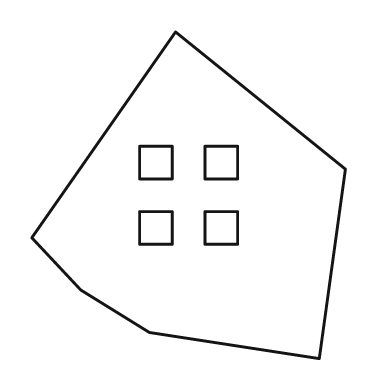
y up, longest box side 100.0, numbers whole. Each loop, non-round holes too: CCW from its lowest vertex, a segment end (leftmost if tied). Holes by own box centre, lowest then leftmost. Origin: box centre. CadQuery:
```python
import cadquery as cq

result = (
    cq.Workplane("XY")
    .moveTo(40.0, -50.0)
    .lineTo(48.0, 8.0)
    .lineTo(-4.0, 50.0)
    .lineTo(-48.0, -13.0)
    .lineTo(-33.0, -29.0)
    .lineTo(-12.0, -42.0)
    .close()
    .moveTo(-15.0, -15.0)
    .lineTo(-5.0, -15.0)
    .lineTo(-5.0, -5.0)
    .lineTo(-15.0, -5.0)
    .close()
    .moveTo(5.0, -15.0)
    .lineTo(15.0, -15.0)
    .lineTo(15.0, -5.0)
    .lineTo(5.0, -5.0)
    .close()
    .moveTo(-15.0, 5.0)
    .lineTo(-5.0, 5.0)
    .lineTo(-5.0, 15.0)
    .lineTo(-15.0, 15.0)
    .close()
    .moveTo(5.0, 5.0)
    .lineTo(15.0, 5.0)
    .lineTo(15.0, 15.0)
    .lineTo(5.0, 15.0)
    .close()
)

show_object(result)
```